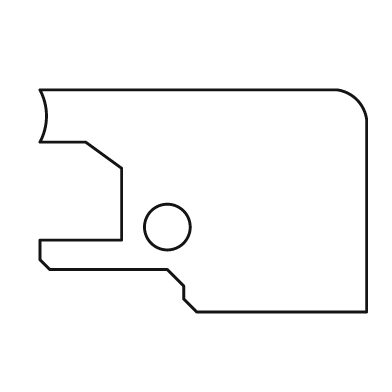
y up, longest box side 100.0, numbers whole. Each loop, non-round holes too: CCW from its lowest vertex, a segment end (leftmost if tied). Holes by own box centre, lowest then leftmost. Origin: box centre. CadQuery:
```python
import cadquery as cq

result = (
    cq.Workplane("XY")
    .moveTo(-2.0, -34.0)
    .lineTo(50.0, -34.0)
    .lineTo(50.0, 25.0)
    .threePointArc((47.0, 31.0), (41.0, 34.0))
    .lineTo(-50.0, 34.0)
    .threePointArc((-48.0, 26.0), (-50.0, 18.0))
    .lineTo(-36.0, 18.0)
    .lineTo(-25.0, 10.0)
    .lineTo(-25.0, -12.0)
    .lineTo(-50.0, -12.0)
    .lineTo(-50.0, -18.0)
    .lineTo(-47.0, -21.0)
    .lineTo(-11.0, -21.0)
    .lineTo(-6.0, -26.0)
    .lineTo(-6.0, -30.0)
    .close()
    .moveTo(-11.0, -8.0)
    .circle(7.0)
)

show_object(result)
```